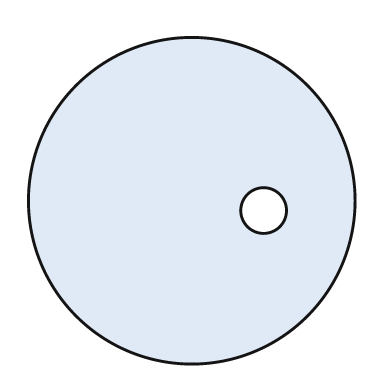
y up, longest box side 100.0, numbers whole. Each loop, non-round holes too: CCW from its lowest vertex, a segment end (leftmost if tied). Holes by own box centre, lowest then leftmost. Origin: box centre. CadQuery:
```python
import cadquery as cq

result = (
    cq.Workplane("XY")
    .moveTo(0.0, 0.0)
    .circle(50.0)
    .moveTo(22.0, -3.0)
    .circle(7.0)
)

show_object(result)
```